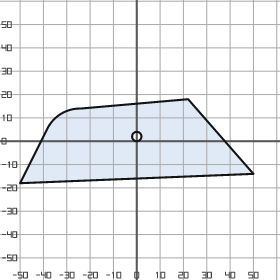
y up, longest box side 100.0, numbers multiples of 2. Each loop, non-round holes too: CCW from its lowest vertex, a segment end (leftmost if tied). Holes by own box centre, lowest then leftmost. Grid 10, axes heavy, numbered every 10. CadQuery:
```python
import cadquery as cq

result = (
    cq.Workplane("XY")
    .moveTo(-50.0, -18.0)
    .lineTo(50.0, -14.0)
    .lineTo(22.0, 18.0)
    .lineTo(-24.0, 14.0)
    .threePointArc((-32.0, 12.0), (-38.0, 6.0))
    .close()
    .moveTo(0.0, 2.0)
    .circle(2.0)
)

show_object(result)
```